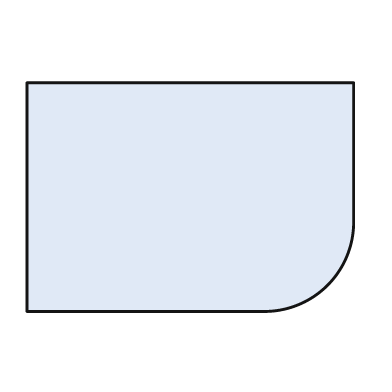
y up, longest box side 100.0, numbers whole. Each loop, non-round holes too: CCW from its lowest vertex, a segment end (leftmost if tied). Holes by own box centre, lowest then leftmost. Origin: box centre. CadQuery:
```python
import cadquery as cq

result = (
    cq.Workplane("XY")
    .moveTo(-50.0, -35.0)
    .lineTo(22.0, -35.0)
    .threePointArc((42.0, -27.0), (50.0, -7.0))
    .lineTo(50.0, 35.0)
    .lineTo(-50.0, 35.0)
    .close()
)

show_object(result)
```